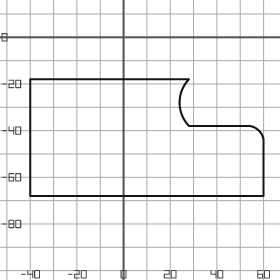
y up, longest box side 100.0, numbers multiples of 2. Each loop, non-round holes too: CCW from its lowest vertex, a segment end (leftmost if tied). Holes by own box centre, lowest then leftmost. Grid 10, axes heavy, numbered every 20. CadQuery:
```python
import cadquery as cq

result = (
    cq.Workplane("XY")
    .moveTo(-40.0, -68.0)
    .lineTo(60.0, -68.0)
    .lineTo(60.0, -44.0)
    .threePointArc((58.0, -40.0), (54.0, -38.0))
    .lineTo(28.0, -38.0)
    .threePointArc((24.0, -28.0), (28.0, -18.0))
    .lineTo(-40.0, -18.0)
    .close()
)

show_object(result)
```